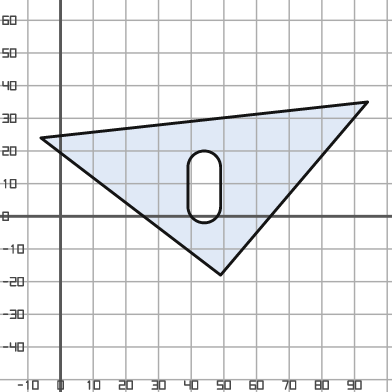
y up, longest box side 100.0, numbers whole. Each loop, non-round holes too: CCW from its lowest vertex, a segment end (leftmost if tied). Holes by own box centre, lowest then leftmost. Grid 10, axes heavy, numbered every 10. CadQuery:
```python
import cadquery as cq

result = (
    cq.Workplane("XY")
    .moveTo(49.0, -18.0)
    .lineTo(94.0, 35.0)
    .lineTo(-6.0, 24.0)
    .close()
    .moveTo(39.0, 3.0)
    .threePointArc((44.0, -2.0), (49.0, 3.0))
    .lineTo(49.0, 15.0)
    .threePointArc((44.0, 20.0), (39.0, 15.0))
    .close()
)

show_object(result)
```